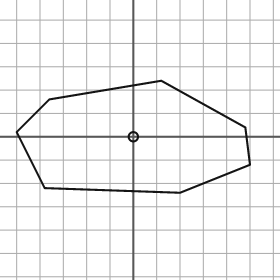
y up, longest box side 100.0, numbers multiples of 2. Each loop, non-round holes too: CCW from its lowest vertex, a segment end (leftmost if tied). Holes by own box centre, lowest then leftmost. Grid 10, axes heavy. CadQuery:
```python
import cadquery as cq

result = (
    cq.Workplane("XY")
    .moveTo(20.0, -24.0)
    .lineTo(50.0, -12.0)
    .lineTo(48.0, 4.0)
    .lineTo(12.0, 24.0)
    .lineTo(-36.0, 16.0)
    .lineTo(-50.0, 2.0)
    .lineTo(-38.0, -22.0)
    .close()
    .moveTo(0.0, 0.0)
    .circle(2.0)
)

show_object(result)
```